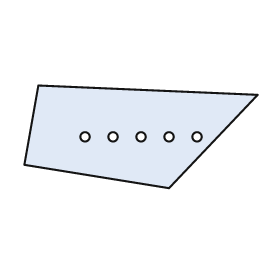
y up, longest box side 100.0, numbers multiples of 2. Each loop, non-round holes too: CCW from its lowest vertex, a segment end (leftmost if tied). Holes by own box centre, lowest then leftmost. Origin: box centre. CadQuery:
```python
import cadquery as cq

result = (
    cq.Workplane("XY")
    .moveTo(12.0, -22.0)
    .lineTo(50.0, 18.0)
    .lineTo(-44.0, 22.0)
    .lineTo(-50.0, -12.0)
    .close()
    .moveTo(-24.0, 0.0)
    .circle(2.0)
    .moveTo(-12.0, 0.0)
    .circle(2.0)
    .moveTo(0.0, 0.0)
    .circle(2.0)
    .moveTo(12.0, 0.0)
    .circle(2.0)
    .moveTo(24.0, 0.0)
    .circle(2.0)
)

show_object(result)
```